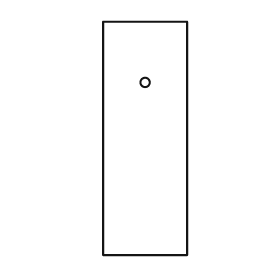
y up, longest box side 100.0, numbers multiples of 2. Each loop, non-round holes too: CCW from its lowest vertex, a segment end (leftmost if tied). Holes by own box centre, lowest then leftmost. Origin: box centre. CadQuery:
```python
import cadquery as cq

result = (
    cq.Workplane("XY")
    .moveTo(-18.0, -50.0)
    .lineTo(18.0, -50.0)
    .lineTo(18.0, 50.0)
    .lineTo(-18.0, 50.0)
    .close()
    .moveTo(0.0, 24.0)
    .circle(2.0)
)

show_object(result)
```